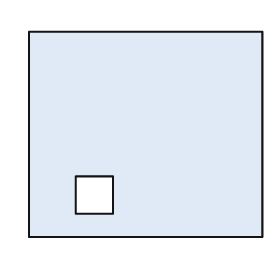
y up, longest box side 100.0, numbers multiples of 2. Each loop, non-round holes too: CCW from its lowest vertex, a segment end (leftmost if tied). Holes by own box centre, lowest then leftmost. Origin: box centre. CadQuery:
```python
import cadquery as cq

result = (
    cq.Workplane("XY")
    .moveTo(-50.0, -44.0)
    .lineTo(50.0, -44.0)
    .lineTo(50.0, 44.0)
    .lineTo(-50.0, 44.0)
    .close()
    .moveTo(-30.0, -34.0)
    .lineTo(-14.0, -34.0)
    .lineTo(-14.0, -18.0)
    .lineTo(-30.0, -18.0)
    .close()
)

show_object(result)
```